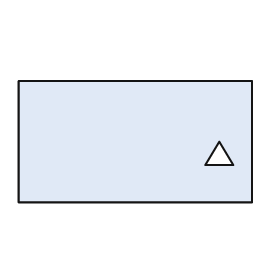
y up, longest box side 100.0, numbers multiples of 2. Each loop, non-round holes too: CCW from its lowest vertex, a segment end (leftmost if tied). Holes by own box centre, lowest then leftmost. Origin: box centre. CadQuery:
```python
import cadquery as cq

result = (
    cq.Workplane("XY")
    .moveTo(-50.0, -26.0)
    .lineTo(50.0, -26.0)
    .lineTo(50.0, 26.0)
    .lineTo(-50.0, 26.0)
    .close()
    .moveTo(30.0, -10.0)
    .lineTo(42.0, -10.0)
    .lineTo(36.0, 0.0)
    .close()
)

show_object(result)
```